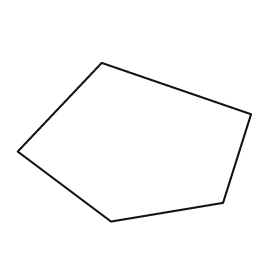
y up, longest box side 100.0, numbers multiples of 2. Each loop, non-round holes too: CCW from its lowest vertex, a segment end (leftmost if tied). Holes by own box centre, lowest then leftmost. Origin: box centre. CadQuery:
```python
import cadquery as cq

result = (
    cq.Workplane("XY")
    .moveTo(-10.0, -34.0)
    .lineTo(38.0, -26.0)
    .lineTo(50.0, 12.0)
    .lineTo(-14.0, 34.0)
    .lineTo(-50.0, -4.0)
    .close()
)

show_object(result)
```